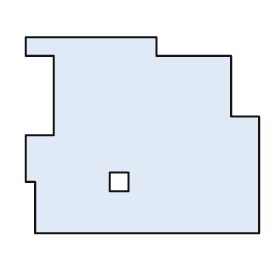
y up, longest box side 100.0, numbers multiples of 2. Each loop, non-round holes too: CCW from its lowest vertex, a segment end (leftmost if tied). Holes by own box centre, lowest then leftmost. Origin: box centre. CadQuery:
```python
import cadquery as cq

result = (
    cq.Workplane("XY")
    .moveTo(-46.0, -42.0)
    .lineTo(50.0, -42.0)
    .lineTo(50.0, 8.0)
    .lineTo(38.0, 8.0)
    .lineTo(38.0, 34.0)
    .lineTo(6.0, 34.0)
    .lineTo(6.0, 42.0)
    .lineTo(-50.0, 42.0)
    .lineTo(-50.0, 34.0)
    .lineTo(-38.0, 34.0)
    .lineTo(-38.0, 0.0)
    .lineTo(-50.0, 0.0)
    .lineTo(-50.0, -20.0)
    .lineTo(-46.0, -20.0)
    .close()
    .moveTo(-14.0, -24.0)
    .lineTo(-6.0, -24.0)
    .lineTo(-6.0, -16.0)
    .lineTo(-14.0, -16.0)
    .close()
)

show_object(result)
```